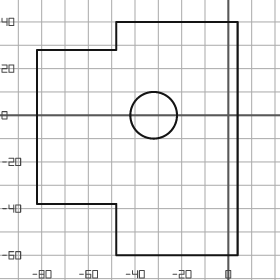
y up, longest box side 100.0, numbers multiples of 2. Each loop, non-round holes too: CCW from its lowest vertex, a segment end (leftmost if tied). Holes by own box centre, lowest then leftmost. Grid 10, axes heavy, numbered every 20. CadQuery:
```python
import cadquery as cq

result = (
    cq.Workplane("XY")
    .moveTo(-48.0, -60.0)
    .lineTo(4.0, -60.0)
    .lineTo(4.0, 40.0)
    .lineTo(-48.0, 40.0)
    .lineTo(-48.0, 28.0)
    .lineTo(-82.0, 28.0)
    .lineTo(-82.0, -38.0)
    .lineTo(-48.0, -38.0)
    .close()
    .moveTo(-32.0, 0.0)
    .circle(10.0)
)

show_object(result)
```